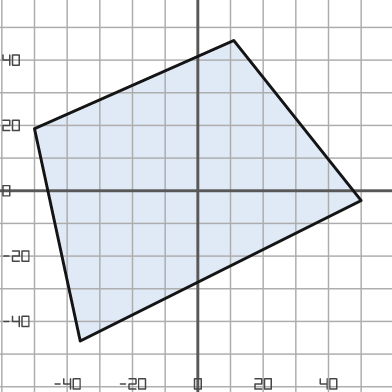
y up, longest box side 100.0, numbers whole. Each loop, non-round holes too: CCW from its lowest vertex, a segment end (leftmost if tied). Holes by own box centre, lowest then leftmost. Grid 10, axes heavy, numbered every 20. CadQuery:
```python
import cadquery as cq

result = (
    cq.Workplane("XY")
    .moveTo(-36.0, -46.0)
    .lineTo(50.0, -3.0)
    .lineTo(11.0, 46.0)
    .lineTo(-50.0, 19.0)
    .close()
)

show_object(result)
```